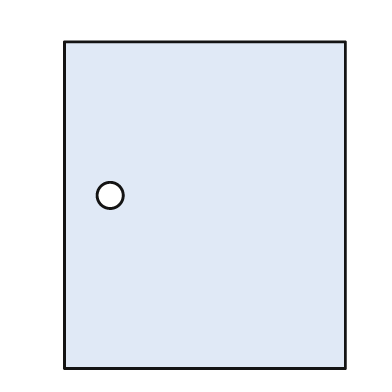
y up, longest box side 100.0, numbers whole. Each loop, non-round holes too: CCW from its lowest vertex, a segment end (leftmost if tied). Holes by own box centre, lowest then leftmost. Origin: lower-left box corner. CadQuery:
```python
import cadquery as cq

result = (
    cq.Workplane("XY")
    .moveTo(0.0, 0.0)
    .lineTo(86.0, 0.0)
    .lineTo(86.0, 100.0)
    .lineTo(0.0, 100.0)
    .close()
    .moveTo(14.0, 53.0)
    .circle(4.0)
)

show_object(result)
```